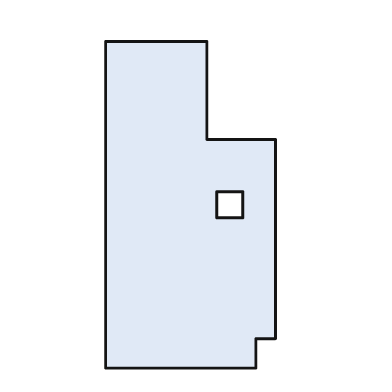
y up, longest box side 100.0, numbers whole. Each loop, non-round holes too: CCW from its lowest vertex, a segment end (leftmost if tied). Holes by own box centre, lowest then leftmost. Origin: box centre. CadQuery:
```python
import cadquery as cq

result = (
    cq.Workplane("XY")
    .moveTo(-26.0, -50.0)
    .lineTo(20.0, -50.0)
    .lineTo(20.0, -41.0)
    .lineTo(26.0, -41.0)
    .lineTo(26.0, 20.0)
    .lineTo(5.0, 20.0)
    .lineTo(5.0, 50.0)
    .lineTo(-26.0, 50.0)
    .close()
    .moveTo(8.0, -4.0)
    .lineTo(16.0, -4.0)
    .lineTo(16.0, 4.0)
    .lineTo(8.0, 4.0)
    .close()
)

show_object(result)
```